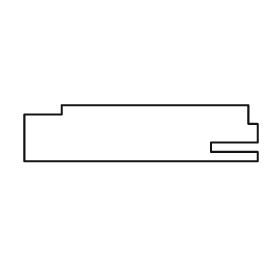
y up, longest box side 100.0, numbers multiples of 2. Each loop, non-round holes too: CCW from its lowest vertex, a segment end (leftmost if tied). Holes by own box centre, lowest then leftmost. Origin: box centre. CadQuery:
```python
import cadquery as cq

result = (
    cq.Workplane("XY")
    .moveTo(-50.0, -12.0)
    .lineTo(50.0, -12.0)
    .lineTo(50.0, -8.0)
    .lineTo(30.0, -8.0)
    .lineTo(30.0, -4.0)
    .lineTo(50.0, -4.0)
    .lineTo(50.0, 4.0)
    .lineTo(46.0, 4.0)
    .lineTo(46.0, 12.0)
    .lineTo(-34.0, 12.0)
    .lineTo(-34.0, 8.0)
    .lineTo(-50.0, 8.0)
    .close()
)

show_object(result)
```